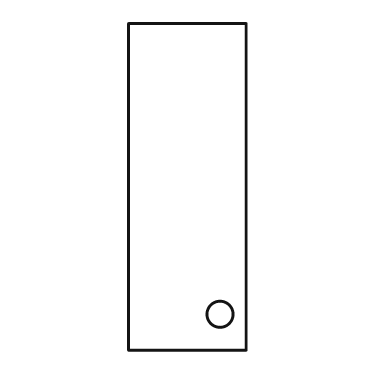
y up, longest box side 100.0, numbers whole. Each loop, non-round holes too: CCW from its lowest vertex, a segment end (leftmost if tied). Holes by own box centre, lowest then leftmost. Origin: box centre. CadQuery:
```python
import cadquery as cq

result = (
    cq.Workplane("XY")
    .moveTo(-18.0, -50.0)
    .lineTo(18.0, -50.0)
    .lineTo(18.0, 50.0)
    .lineTo(-18.0, 50.0)
    .close()
    .moveTo(10.0, -39.0)
    .circle(4.0)
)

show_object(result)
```